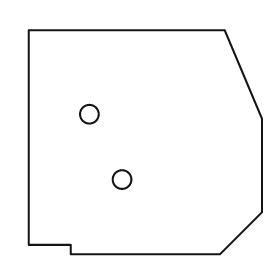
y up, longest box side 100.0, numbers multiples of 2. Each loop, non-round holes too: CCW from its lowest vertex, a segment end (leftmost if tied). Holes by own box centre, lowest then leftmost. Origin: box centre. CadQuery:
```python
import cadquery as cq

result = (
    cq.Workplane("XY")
    .moveTo(-32.0, -48.0)
    .lineTo(32.0, -48.0)
    .lineTo(50.0, -30.0)
    .lineTo(50.0, 10.0)
    .lineTo(34.0, 48.0)
    .lineTo(-50.0, 48.0)
    .lineTo(-50.0, -44.0)
    .lineTo(-32.0, -44.0)
    .close()
    .moveTo(-10.0, -16.0)
    .circle(4.0)
    .moveTo(-24.0, 12.0)
    .circle(4.0)
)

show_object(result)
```